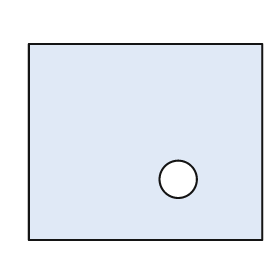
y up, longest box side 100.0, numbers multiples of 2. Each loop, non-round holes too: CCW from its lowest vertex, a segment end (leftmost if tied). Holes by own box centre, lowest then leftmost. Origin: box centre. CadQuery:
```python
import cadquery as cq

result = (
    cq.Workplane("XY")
    .moveTo(-50.0, -42.0)
    .lineTo(50.0, -42.0)
    .lineTo(50.0, 42.0)
    .lineTo(-50.0, 42.0)
    .close()
    .moveTo(14.0, -16.0)
    .circle(8.0)
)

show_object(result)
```